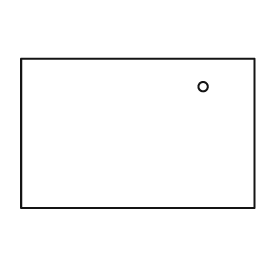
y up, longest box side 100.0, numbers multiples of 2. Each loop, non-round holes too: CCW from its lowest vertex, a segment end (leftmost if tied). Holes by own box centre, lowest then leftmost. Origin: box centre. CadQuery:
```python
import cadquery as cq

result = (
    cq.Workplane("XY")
    .moveTo(-50.0, -32.0)
    .lineTo(50.0, -32.0)
    .lineTo(50.0, 32.0)
    .lineTo(-50.0, 32.0)
    .close()
    .moveTo(28.0, 20.0)
    .circle(2.0)
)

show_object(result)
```